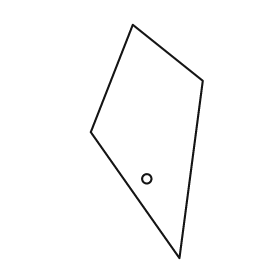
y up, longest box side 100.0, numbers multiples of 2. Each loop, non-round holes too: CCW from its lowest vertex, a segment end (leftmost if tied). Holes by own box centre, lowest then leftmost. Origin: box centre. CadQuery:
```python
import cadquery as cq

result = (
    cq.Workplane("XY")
    .moveTo(14.0, -50.0)
    .lineTo(24.0, 26.0)
    .lineTo(-6.0, 50.0)
    .lineTo(-24.0, 4.0)
    .close()
    .moveTo(0.0, -16.0)
    .circle(2.0)
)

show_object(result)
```